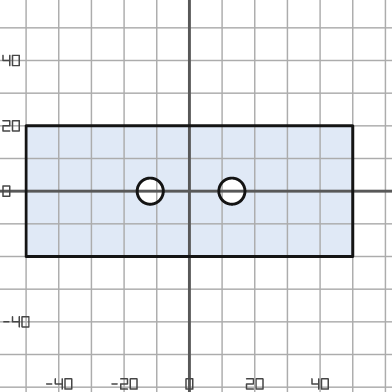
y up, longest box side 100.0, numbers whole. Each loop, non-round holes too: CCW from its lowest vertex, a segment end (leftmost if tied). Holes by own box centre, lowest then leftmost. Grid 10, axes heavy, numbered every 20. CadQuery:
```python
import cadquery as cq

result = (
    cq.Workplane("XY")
    .moveTo(-50.0, -20.0)
    .lineTo(50.0, -20.0)
    .lineTo(50.0, 20.0)
    .lineTo(-50.0, 20.0)
    .close()
    .moveTo(-12.0, 0.0)
    .circle(4.0)
    .moveTo(13.0, 0.0)
    .circle(4.0)
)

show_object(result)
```